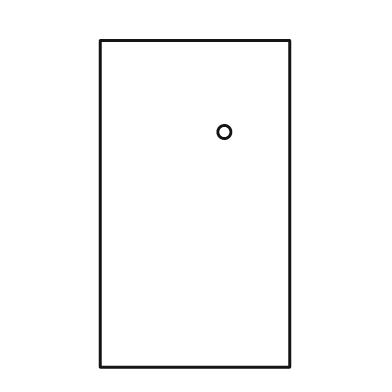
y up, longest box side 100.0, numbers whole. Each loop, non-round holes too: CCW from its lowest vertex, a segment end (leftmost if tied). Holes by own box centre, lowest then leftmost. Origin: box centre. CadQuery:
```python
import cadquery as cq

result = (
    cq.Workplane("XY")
    .moveTo(-29.0, -50.0)
    .lineTo(29.0, -50.0)
    .lineTo(29.0, 50.0)
    .lineTo(-29.0, 50.0)
    .close()
    .moveTo(9.0, 22.0)
    .circle(2.0)
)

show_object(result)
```